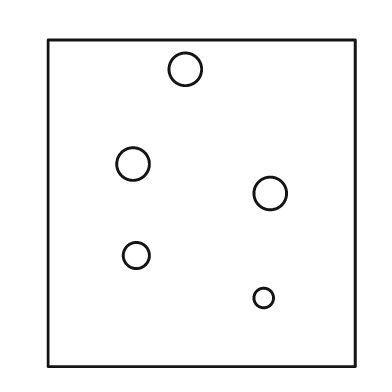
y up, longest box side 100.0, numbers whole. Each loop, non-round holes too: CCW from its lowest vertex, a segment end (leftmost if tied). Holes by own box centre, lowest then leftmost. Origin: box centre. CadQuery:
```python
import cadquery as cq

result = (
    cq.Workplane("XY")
    .moveTo(-47.0, -50.0)
    .lineTo(47.0, -50.0)
    .lineTo(47.0, 50.0)
    .lineTo(-47.0, 50.0)
    .close()
    .moveTo(19.0, -29.0)
    .circle(3.0)
    .moveTo(-20.0, -16.0)
    .circle(4.0)
    .moveTo(21.0, 3.0)
    .circle(5.0)
    .moveTo(-21.0, 12.0)
    .circle(5.0)
    .moveTo(-5.0, 41.0)
    .circle(5.0)
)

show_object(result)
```